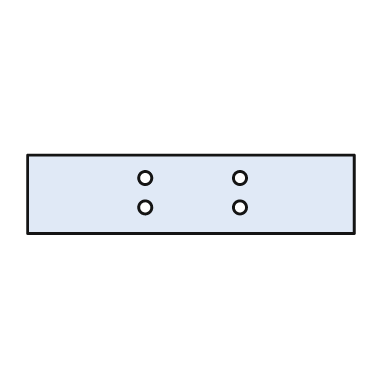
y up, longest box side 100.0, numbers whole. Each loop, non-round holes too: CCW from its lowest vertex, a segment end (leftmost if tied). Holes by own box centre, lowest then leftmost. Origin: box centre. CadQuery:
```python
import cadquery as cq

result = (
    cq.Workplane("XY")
    .moveTo(-50.0, -12.0)
    .lineTo(50.0, -12.0)
    .lineTo(50.0, 12.0)
    .lineTo(-50.0, 12.0)
    .close()
    .moveTo(-14.0, -4.0)
    .circle(2.0)
    .moveTo(15.0, -4.0)
    .circle(2.0)
    .moveTo(-14.0, 5.0)
    .circle(2.0)
    .moveTo(15.0, 5.0)
    .circle(2.0)
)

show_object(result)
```